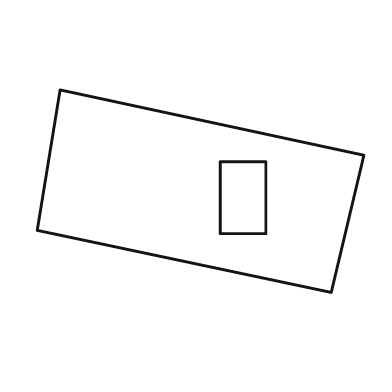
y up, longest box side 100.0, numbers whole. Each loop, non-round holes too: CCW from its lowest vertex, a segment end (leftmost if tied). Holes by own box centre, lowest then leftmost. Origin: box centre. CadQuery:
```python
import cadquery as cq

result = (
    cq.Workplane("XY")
    .moveTo(40.0, -31.0)
    .lineTo(50.0, 11.0)
    .lineTo(-43.0, 31.0)
    .lineTo(-50.0, -12.0)
    .close()
    .moveTo(6.0, -13.0)
    .lineTo(20.0, -13.0)
    .lineTo(20.0, 9.0)
    .lineTo(6.0, 9.0)
    .close()
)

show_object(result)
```